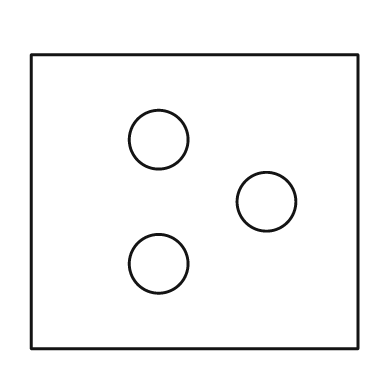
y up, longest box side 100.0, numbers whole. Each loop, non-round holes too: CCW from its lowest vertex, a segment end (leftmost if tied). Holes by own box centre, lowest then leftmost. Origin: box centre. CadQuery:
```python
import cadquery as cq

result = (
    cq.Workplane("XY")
    .moveTo(-50.0, -45.0)
    .lineTo(50.0, -45.0)
    .lineTo(50.0, 45.0)
    .lineTo(-50.0, 45.0)
    .close()
    .moveTo(-11.0, -19.0)
    .circle(9.0)
    .moveTo(22.0, 0.0)
    .circle(9.0)
    .moveTo(-11.0, 19.0)
    .circle(9.0)
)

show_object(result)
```